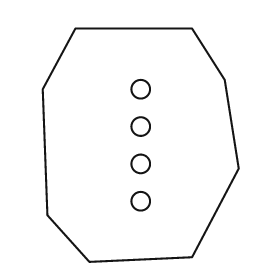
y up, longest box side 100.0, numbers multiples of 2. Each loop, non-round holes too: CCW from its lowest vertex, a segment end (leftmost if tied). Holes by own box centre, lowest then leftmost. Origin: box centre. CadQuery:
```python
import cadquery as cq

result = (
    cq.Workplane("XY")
    .moveTo(-22.0, -50.0)
    .lineTo(22.0, -48.0)
    .lineTo(42.0, -10.0)
    .lineTo(36.0, 28.0)
    .lineTo(22.0, 50.0)
    .lineTo(-28.0, 50.0)
    .lineTo(-42.0, 24.0)
    .lineTo(-40.0, -30.0)
    .close()
    .moveTo(0.0, -24.0)
    .circle(4.0)
    .moveTo(0.0, -8.0)
    .circle(4.0)
    .moveTo(0.0, 8.0)
    .circle(4.0)
    .moveTo(0.0, 24.0)
    .circle(4.0)
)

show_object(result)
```